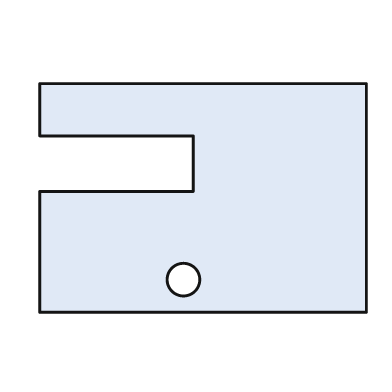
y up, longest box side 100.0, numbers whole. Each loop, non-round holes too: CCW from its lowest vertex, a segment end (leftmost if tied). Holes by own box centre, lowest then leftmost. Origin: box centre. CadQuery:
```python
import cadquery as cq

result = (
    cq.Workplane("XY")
    .moveTo(-50.0, -35.0)
    .lineTo(50.0, -35.0)
    .lineTo(50.0, 35.0)
    .lineTo(-50.0, 35.0)
    .lineTo(-50.0, 19.0)
    .lineTo(-3.0, 19.0)
    .lineTo(-3.0, 2.0)
    .lineTo(-50.0, 2.0)
    .close()
    .moveTo(-6.0, -25.0)
    .circle(5.0)
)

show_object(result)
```